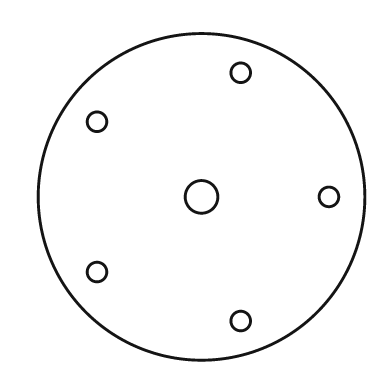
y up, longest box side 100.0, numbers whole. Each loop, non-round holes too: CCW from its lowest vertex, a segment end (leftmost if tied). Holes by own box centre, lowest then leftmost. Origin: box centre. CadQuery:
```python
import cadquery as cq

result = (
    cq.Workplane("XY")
    .moveTo(0.0, 0.0)
    .circle(50.0)
    .moveTo(12.0, -38.0)
    .circle(3.0)
    .moveTo(-32.0, -23.0)
    .circle(3.0)
    .moveTo(0.0, 0.0)
    .circle(5.0)
    .moveTo(39.0, 0.0)
    .circle(3.0)
    .moveTo(-32.0, 23.0)
    .circle(3.0)
    .moveTo(12.0, 38.0)
    .circle(3.0)
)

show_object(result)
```